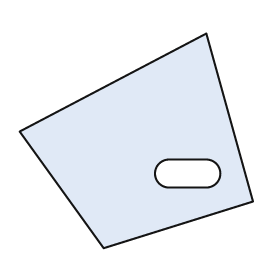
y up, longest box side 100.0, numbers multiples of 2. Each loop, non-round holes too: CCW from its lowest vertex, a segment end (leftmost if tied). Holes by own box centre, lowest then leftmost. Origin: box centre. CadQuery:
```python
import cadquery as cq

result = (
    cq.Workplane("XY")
    .moveTo(-14.0, -46.0)
    .lineTo(50.0, -26.0)
    .lineTo(30.0, 46.0)
    .lineTo(-50.0, 4.0)
    .close()
    .moveTo(14.0, -20.0)
    .lineTo(30.0, -20.0)
    .threePointArc((36.0, -14.0), (30.0, -8.0))
    .lineTo(14.0, -8.0)
    .threePointArc((8.0, -14.0), (14.0, -20.0))
    .close()
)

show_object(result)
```